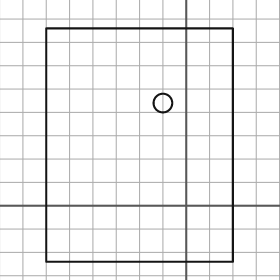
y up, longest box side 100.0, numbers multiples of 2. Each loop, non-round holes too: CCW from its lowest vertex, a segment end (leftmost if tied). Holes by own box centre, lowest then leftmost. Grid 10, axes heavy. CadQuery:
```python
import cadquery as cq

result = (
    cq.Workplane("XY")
    .moveTo(-60.0, -24.0)
    .lineTo(20.0, -24.0)
    .lineTo(20.0, 76.0)
    .lineTo(-60.0, 76.0)
    .close()
    .moveTo(-10.0, 44.0)
    .circle(4.0)
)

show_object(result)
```